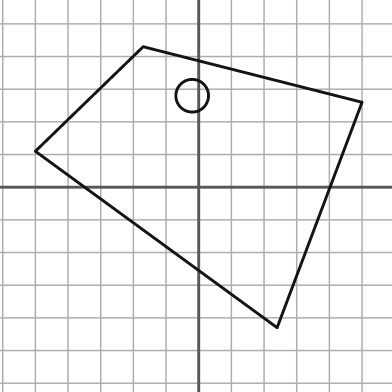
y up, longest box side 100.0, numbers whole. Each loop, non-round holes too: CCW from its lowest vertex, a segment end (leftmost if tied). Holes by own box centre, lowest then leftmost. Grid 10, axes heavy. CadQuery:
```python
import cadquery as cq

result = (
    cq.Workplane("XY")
    .moveTo(24.0, -43.0)
    .lineTo(50.0, 26.0)
    .lineTo(-17.0, 43.0)
    .lineTo(-50.0, 11.0)
    .close()
    .moveTo(-2.0, 28.0)
    .circle(5.0)
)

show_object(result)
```